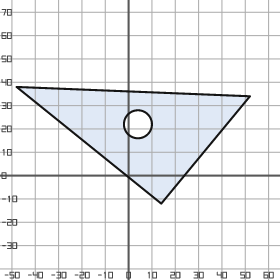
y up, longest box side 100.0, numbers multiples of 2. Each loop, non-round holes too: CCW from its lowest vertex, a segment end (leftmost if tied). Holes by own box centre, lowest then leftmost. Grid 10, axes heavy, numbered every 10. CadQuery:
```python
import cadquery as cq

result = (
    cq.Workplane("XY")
    .moveTo(14.0, -12.0)
    .lineTo(52.0, 34.0)
    .lineTo(-48.0, 38.0)
    .close()
    .moveTo(4.0, 22.0)
    .circle(6.0)
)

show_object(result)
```